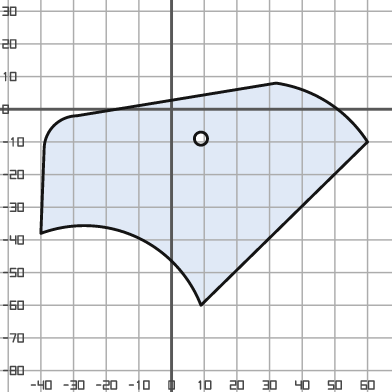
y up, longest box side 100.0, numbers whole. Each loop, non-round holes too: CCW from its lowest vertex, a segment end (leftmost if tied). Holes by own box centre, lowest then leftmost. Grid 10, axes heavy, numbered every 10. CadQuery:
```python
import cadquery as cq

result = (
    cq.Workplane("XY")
    .moveTo(9.0, -60.0)
    .lineTo(60.0, -10.0)
    .threePointArc((48.0, 2.0), (32.0, 8.0))
    .lineTo(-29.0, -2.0)
    .threePointArc((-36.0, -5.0), (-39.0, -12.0))
    .lineTo(-40.0, -38.0)
    .threePointArc((-11.0, -39.0), (9.0, -60.0))
    .close()
    .moveTo(9.0, -9.0)
    .circle(2.0)
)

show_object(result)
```